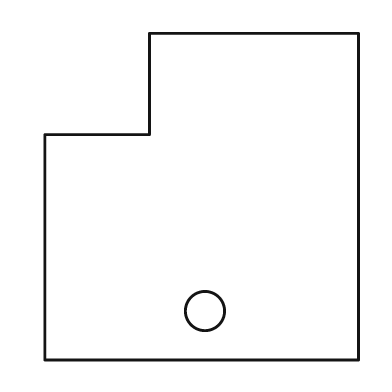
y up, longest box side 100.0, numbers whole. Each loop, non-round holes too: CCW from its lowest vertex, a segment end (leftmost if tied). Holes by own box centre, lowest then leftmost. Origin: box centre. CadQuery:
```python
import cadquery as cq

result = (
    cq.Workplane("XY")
    .moveTo(-48.0, -50.0)
    .lineTo(48.0, -50.0)
    .lineTo(48.0, 50.0)
    .lineTo(-16.0, 50.0)
    .lineTo(-16.0, 19.0)
    .lineTo(-48.0, 19.0)
    .close()
    .moveTo(1.0, -35.0)
    .circle(6.0)
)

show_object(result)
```